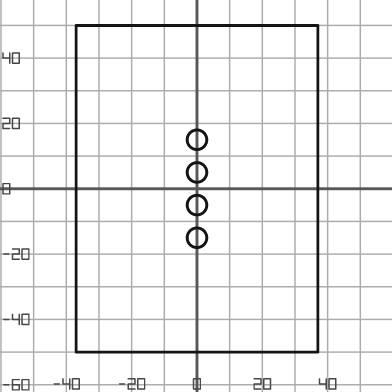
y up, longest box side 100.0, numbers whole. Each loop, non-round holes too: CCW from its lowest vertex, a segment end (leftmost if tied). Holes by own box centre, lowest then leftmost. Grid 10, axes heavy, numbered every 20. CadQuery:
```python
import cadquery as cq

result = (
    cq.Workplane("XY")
    .moveTo(-37.0, -50.0)
    .lineTo(37.0, -50.0)
    .lineTo(37.0, 50.0)
    .lineTo(-37.0, 50.0)
    .close()
    .moveTo(0.0, -15.0)
    .circle(3.0)
    .moveTo(0.0, -5.0)
    .circle(3.0)
    .moveTo(0.0, 5.0)
    .circle(3.0)
    .moveTo(0.0, 15.0)
    .circle(3.0)
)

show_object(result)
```